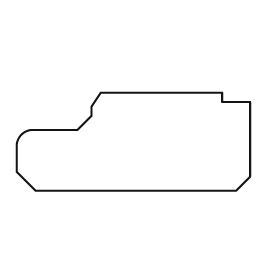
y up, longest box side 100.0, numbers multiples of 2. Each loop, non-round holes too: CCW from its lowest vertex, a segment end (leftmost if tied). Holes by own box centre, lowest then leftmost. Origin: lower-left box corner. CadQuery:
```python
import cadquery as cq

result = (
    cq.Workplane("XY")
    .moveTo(8.0, 0.0)
    .lineTo(94.0, 0.0)
    .lineTo(100.0, 6.0)
    .lineTo(100.0, 38.0)
    .lineTo(88.0, 38.0)
    .lineTo(88.0, 42.0)
    .lineTo(36.0, 42.0)
    .lineTo(32.0, 36.0)
    .lineTo(32.0, 32.0)
    .lineTo(26.0, 26.0)
    .lineTo(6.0, 26.0)
    .threePointArc((2.0, 24.0), (0.0, 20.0))
    .lineTo(0.0, 8.0)
    .close()
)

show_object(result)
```